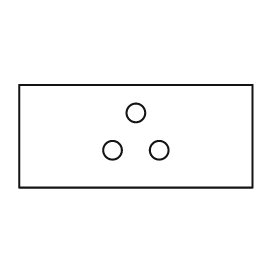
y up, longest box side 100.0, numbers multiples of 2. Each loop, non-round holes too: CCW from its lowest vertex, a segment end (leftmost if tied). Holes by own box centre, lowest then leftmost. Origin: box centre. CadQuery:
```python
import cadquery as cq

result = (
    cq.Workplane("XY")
    .moveTo(-50.0, -22.0)
    .lineTo(50.0, -22.0)
    .lineTo(50.0, 22.0)
    .lineTo(-50.0, 22.0)
    .close()
    .moveTo(-10.0, -6.0)
    .circle(4.0)
    .moveTo(10.0, -6.0)
    .circle(4.0)
    .moveTo(0.0, 10.0)
    .circle(4.0)
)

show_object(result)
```